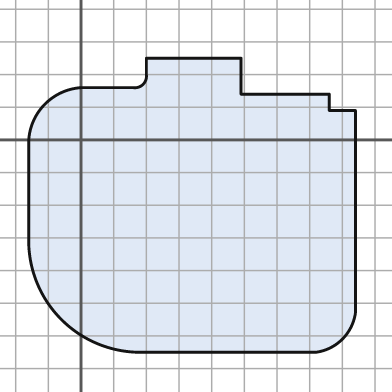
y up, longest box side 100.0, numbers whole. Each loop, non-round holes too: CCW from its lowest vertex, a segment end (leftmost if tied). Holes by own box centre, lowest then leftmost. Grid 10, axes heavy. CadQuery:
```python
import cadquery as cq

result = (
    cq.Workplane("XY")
    .moveTo(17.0, -65.0)
    .lineTo(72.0, -65.0)
    .threePointArc((80.0, -61.0), (84.0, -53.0))
    .lineTo(84.0, 9.0)
    .lineTo(76.0, 9.0)
    .lineTo(76.0, 14.0)
    .lineTo(49.0, 14.0)
    .lineTo(49.0, 25.0)
    .lineTo(20.0, 25.0)
    .lineTo(20.0, 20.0)
    .threePointArc((19.0, 17.0), (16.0, 16.0))
    .lineTo(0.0, 16.0)
    .threePointArc((-11.0, 11.0), (-16.0, 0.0))
    .lineTo(-16.0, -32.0)
    .threePointArc((-6.0, -55.0), (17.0, -65.0))
    .close()
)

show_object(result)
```